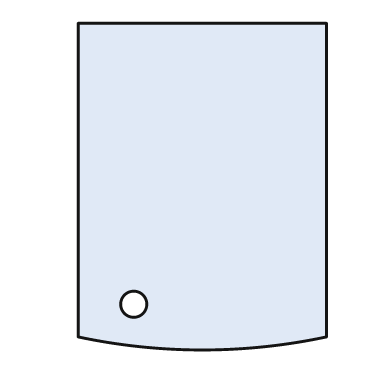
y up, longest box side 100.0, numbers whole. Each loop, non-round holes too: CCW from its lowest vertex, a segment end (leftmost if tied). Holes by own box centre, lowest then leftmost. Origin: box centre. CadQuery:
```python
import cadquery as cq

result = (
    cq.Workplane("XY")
    .moveTo(-38.0, -46.0)
    .threePointArc((0.0, -50.0), (38.0, -46.0))
    .lineTo(38.0, 50.0)
    .lineTo(-38.0, 50.0)
    .close()
    .moveTo(-21.0, -36.0)
    .circle(4.0)
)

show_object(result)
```